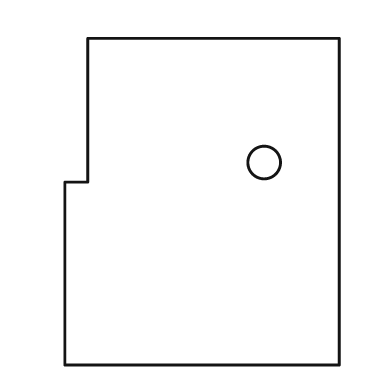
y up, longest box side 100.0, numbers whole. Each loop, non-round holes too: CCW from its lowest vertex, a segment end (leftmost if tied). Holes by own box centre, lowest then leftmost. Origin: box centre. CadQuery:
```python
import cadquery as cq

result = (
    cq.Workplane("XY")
    .moveTo(-42.0, -50.0)
    .lineTo(42.0, -50.0)
    .lineTo(42.0, 50.0)
    .lineTo(-35.0, 50.0)
    .lineTo(-35.0, 6.0)
    .lineTo(-42.0, 6.0)
    .close()
    .moveTo(19.0, 12.0)
    .circle(5.0)
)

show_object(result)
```